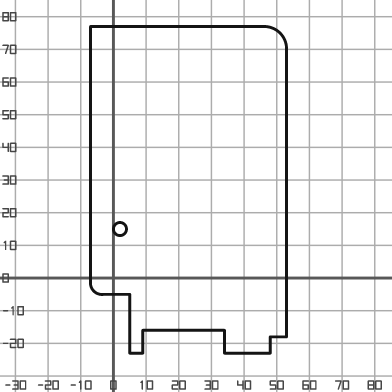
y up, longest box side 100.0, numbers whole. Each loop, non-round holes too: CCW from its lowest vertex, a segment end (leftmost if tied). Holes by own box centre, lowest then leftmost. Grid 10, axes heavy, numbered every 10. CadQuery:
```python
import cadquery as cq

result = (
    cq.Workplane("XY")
    .moveTo(5.0, -23.0)
    .lineTo(9.0, -23.0)
    .lineTo(9.0, -16.0)
    .lineTo(34.0, -16.0)
    .lineTo(34.0, -23.0)
    .lineTo(48.0, -23.0)
    .lineTo(48.0, -18.0)
    .lineTo(53.0, -18.0)
    .lineTo(53.0, 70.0)
    .threePointArc((51.0, 75.0), (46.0, 77.0))
    .lineTo(-7.0, 77.0)
    .lineTo(-7.0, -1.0)
    .threePointArc((-6.0, -4.0), (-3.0, -5.0))
    .lineTo(5.0, -5.0)
    .close()
    .moveTo(2.0, 15.0)
    .circle(2.0)
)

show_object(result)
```